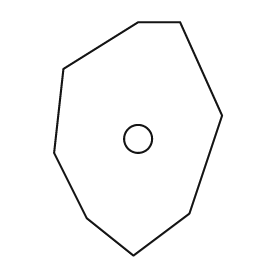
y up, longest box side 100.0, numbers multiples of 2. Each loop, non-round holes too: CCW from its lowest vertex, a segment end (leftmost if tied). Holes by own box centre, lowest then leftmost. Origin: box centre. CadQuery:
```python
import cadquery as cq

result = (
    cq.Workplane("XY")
    .moveTo(-2.0, -50.0)
    .lineTo(22.0, -32.0)
    .lineTo(36.0, 10.0)
    .lineTo(18.0, 50.0)
    .lineTo(0.0, 50.0)
    .lineTo(-32.0, 30.0)
    .lineTo(-36.0, -6.0)
    .lineTo(-22.0, -34.0)
    .close()
    .moveTo(0.0, 0.0)
    .circle(6.0)
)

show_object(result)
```